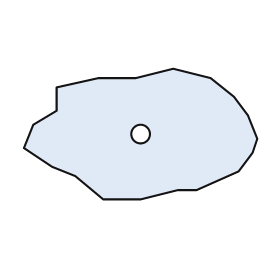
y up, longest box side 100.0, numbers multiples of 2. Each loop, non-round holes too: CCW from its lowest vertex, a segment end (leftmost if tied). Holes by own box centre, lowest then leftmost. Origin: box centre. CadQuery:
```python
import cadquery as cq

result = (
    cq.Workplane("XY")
    .moveTo(-16.0, -28.0)
    .lineTo(0.0, -28.0)
    .lineTo(16.0, -24.0)
    .lineTo(24.0, -24.0)
    .lineTo(42.0, -16.0)
    .lineTo(48.0, -8.0)
    .lineTo(50.0, -2.0)
    .lineTo(46.0, 8.0)
    .lineTo(40.0, 16.0)
    .lineTo(30.0, 24.0)
    .lineTo(14.0, 28.0)
    .lineTo(-2.0, 24.0)
    .lineTo(-18.0, 24.0)
    .lineTo(-36.0, 20.0)
    .lineTo(-36.0, 10.0)
    .lineTo(-46.0, 4.0)
    .lineTo(-50.0, -6.0)
    .lineTo(-38.0, -14.0)
    .lineTo(-28.0, -18.0)
    .close()
    .moveTo(0.0, 0.0)
    .circle(4.0)
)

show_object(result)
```